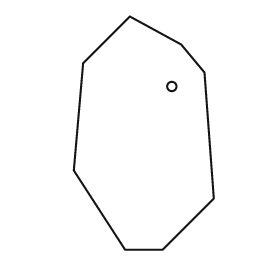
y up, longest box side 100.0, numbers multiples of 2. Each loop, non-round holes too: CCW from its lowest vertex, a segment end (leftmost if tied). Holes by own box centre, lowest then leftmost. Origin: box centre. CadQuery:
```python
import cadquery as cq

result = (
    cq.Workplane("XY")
    .moveTo(-8.0, -50.0)
    .lineTo(8.0, -50.0)
    .lineTo(30.0, -28.0)
    .lineTo(26.0, 26.0)
    .lineTo(16.0, 38.0)
    .lineTo(-6.0, 50.0)
    .lineTo(-26.0, 30.0)
    .lineTo(-30.0, -16.0)
    .close()
    .moveTo(12.0, 20.0)
    .circle(2.0)
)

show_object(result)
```